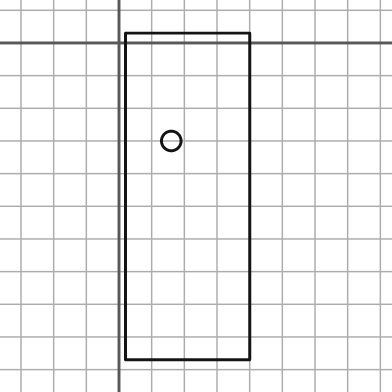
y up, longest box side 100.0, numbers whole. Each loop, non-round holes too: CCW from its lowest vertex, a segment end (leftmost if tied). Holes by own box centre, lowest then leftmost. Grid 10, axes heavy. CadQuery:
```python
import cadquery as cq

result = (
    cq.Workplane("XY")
    .moveTo(2.0, -97.0)
    .lineTo(40.0, -97.0)
    .lineTo(40.0, 3.0)
    .lineTo(2.0, 3.0)
    .close()
    .moveTo(16.0, -30.0)
    .circle(3.0)
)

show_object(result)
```